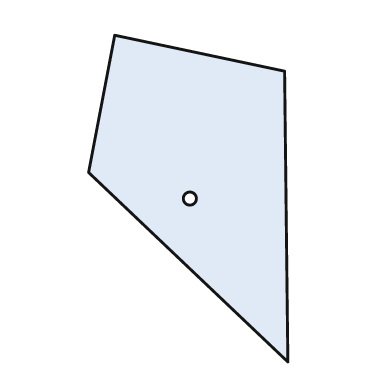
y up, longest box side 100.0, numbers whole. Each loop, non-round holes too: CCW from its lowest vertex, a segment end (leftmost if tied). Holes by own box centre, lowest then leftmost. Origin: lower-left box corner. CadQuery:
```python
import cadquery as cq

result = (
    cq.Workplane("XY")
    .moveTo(61.0, 0.0)
    .lineTo(60.0, 89.0)
    .lineTo(8.0, 100.0)
    .lineTo(0.0, 58.0)
    .close()
    .moveTo(31.0, 50.0)
    .circle(2.0)
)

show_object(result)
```